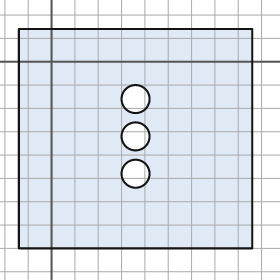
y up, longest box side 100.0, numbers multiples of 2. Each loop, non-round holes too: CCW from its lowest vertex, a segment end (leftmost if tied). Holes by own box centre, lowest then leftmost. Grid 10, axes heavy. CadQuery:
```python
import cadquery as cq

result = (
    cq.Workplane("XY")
    .moveTo(-14.0, -80.0)
    .lineTo(86.0, -80.0)
    .lineTo(86.0, 14.0)
    .lineTo(-14.0, 14.0)
    .close()
    .moveTo(36.0, -48.0)
    .circle(6.0)
    .moveTo(36.0, -32.0)
    .circle(6.0)
    .moveTo(36.0, -16.0)
    .circle(6.0)
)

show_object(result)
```